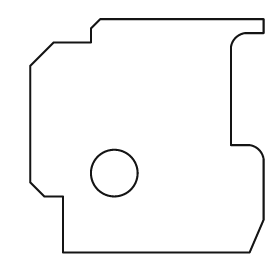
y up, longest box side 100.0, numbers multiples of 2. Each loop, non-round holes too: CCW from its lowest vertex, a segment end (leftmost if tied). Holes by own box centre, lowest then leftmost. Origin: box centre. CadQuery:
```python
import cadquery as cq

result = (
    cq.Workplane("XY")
    .moveTo(-36.0, -50.0)
    .lineTo(44.0, -50.0)
    .lineTo(50.0, -36.0)
    .lineTo(50.0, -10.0)
    .threePointArc((48.0, -6.0), (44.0, -4.0))
    .lineTo(36.0, -4.0)
    .lineTo(36.0, 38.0)
    .threePointArc((38.0, 42.0), (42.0, 44.0))
    .lineTo(50.0, 44.0)
    .lineTo(50.0, 50.0)
    .lineTo(-20.0, 50.0)
    .lineTo(-24.0, 46.0)
    .lineTo(-24.0, 40.0)
    .lineTo(-40.0, 40.0)
    .lineTo(-50.0, 30.0)
    .lineTo(-50.0, -20.0)
    .lineTo(-44.0, -26.0)
    .lineTo(-36.0, -26.0)
    .close()
    .moveTo(-14.0, -16.0)
    .circle(10.0)
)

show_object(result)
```